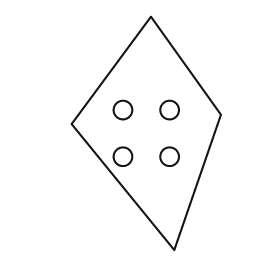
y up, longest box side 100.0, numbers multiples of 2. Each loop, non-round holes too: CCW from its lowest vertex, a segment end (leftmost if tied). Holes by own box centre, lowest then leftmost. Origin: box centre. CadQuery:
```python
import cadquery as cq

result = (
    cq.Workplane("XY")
    .moveTo(12.0, -50.0)
    .lineTo(32.0, 8.0)
    .lineTo(2.0, 50.0)
    .lineTo(-32.0, 4.0)
    .close()
    .moveTo(-10.0, -10.0)
    .circle(4.0)
    .moveTo(10.0, -10.0)
    .circle(4.0)
    .moveTo(-10.0, 10.0)
    .circle(4.0)
    .moveTo(10.0, 10.0)
    .circle(4.0)
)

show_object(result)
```